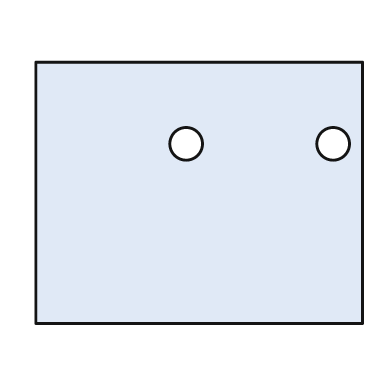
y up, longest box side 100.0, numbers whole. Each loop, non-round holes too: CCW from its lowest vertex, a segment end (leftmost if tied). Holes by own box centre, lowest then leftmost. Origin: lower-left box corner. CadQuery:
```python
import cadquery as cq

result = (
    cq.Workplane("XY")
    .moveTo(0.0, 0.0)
    .lineTo(100.0, 0.0)
    .lineTo(100.0, 80.0)
    .lineTo(0.0, 80.0)
    .close()
    .moveTo(46.0, 55.0)
    .circle(5.0)
    .moveTo(91.0, 55.0)
    .circle(5.0)
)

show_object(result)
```